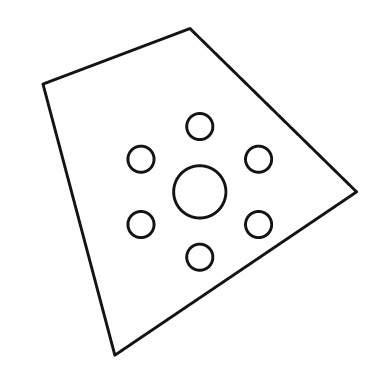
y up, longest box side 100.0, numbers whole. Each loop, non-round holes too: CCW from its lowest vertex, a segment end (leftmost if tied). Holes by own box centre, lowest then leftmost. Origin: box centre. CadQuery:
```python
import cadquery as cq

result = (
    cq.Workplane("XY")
    .moveTo(-26.0, -50.0)
    .lineTo(48.0, 0.0)
    .lineTo(-3.0, 50.0)
    .lineTo(-48.0, 33.0)
    .close()
    .moveTo(0.0, -20.0)
    .circle(4.0)
    .moveTo(-18.0, -10.0)
    .circle(4.0)
    .moveTo(18.0, -10.0)
    .circle(4.0)
    .moveTo(0.0, 0.0)
    .circle(8.0)
    .moveTo(-18.0, 10.0)
    .circle(4.0)
    .moveTo(18.0, 10.0)
    .circle(4.0)
    .moveTo(0.0, 20.0)
    .circle(4.0)
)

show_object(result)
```